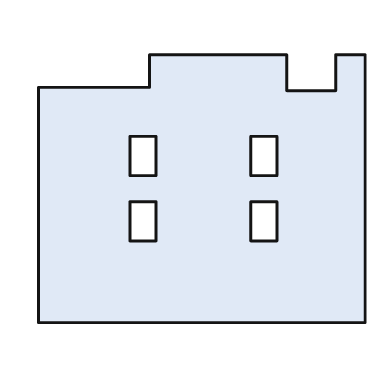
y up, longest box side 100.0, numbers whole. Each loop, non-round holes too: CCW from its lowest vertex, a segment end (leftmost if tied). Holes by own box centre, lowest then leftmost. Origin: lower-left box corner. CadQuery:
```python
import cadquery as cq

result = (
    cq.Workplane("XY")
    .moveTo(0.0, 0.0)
    .lineTo(100.0, 0.0)
    .lineTo(100.0, 82.0)
    .lineTo(91.0, 82.0)
    .lineTo(91.0, 71.0)
    .lineTo(76.0, 71.0)
    .lineTo(76.0, 82.0)
    .lineTo(34.0, 82.0)
    .lineTo(34.0, 72.0)
    .lineTo(0.0, 72.0)
    .close()
    .moveTo(28.0, 25.0)
    .lineTo(36.0, 25.0)
    .lineTo(36.0, 37.0)
    .lineTo(28.0, 37.0)
    .close()
    .moveTo(65.0, 25.0)
    .lineTo(73.0, 25.0)
    .lineTo(73.0, 37.0)
    .lineTo(65.0, 37.0)
    .close()
    .moveTo(28.0, 45.0)
    .lineTo(36.0, 45.0)
    .lineTo(36.0, 57.0)
    .lineTo(28.0, 57.0)
    .close()
    .moveTo(65.0, 45.0)
    .lineTo(73.0, 45.0)
    .lineTo(73.0, 57.0)
    .lineTo(65.0, 57.0)
    .close()
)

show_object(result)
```